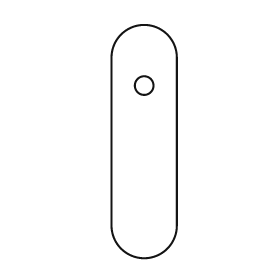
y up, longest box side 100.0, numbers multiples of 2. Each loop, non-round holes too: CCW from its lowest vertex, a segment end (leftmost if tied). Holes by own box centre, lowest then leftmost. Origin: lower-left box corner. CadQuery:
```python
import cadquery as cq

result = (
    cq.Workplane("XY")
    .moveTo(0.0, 14.0)
    .threePointArc((14.0, 0.0), (28.0, 14.0))
    .lineTo(28.0, 86.0)
    .threePointArc((14.0, 100.0), (0.0, 86.0))
    .close()
    .moveTo(14.0, 74.0)
    .circle(4.0)
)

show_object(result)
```